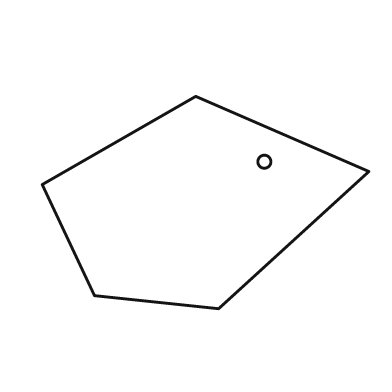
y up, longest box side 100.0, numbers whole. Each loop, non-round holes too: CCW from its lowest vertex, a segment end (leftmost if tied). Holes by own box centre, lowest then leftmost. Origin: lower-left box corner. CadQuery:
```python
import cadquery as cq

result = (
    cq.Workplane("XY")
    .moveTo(54.0, 0.0)
    .lineTo(100.0, 42.0)
    .lineTo(47.0, 65.0)
    .lineTo(0.0, 38.0)
    .lineTo(16.0, 4.0)
    .close()
    .moveTo(68.0, 45.0)
    .circle(2.0)
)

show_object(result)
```